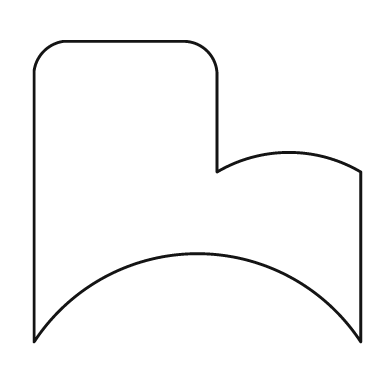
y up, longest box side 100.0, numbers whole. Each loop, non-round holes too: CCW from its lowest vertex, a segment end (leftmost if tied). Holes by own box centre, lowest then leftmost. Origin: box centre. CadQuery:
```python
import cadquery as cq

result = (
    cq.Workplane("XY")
    .moveTo(-50.0, -46.0)
    .threePointArc((0.0, -19.0), (50.0, -46.0))
    .lineTo(50.0, 6.0)
    .threePointArc((28.0, 12.0), (6.0, 6.0))
    .lineTo(6.0, 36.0)
    .threePointArc((3.0, 43.0), (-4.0, 46.0))
    .lineTo(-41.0, 46.0)
    .threePointArc((-47.0, 43.0), (-50.0, 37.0))
    .close()
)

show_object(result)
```